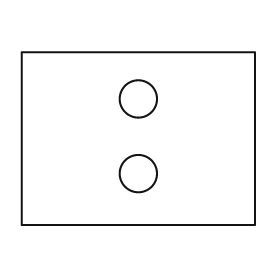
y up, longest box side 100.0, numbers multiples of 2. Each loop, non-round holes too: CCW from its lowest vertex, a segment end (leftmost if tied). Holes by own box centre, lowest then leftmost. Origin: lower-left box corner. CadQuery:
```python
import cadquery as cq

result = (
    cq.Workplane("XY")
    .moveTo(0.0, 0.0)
    .lineTo(100.0, 0.0)
    .lineTo(100.0, 74.0)
    .lineTo(0.0, 74.0)
    .close()
    .moveTo(50.0, 22.0)
    .circle(8.0)
    .moveTo(50.0, 54.0)
    .circle(8.0)
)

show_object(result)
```